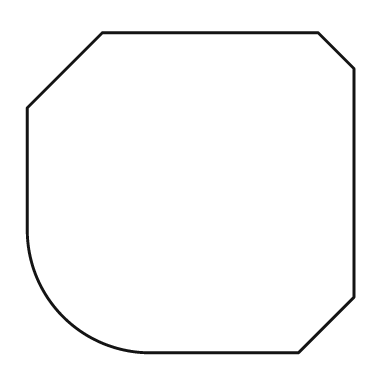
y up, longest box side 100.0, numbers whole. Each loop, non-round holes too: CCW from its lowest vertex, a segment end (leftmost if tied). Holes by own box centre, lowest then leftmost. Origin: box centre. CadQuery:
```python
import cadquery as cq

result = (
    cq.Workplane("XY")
    .moveTo(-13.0, -49.0)
    .lineTo(33.0, -49.0)
    .lineTo(50.0, -32.0)
    .lineTo(50.0, 38.0)
    .lineTo(39.0, 49.0)
    .lineTo(-27.0, 49.0)
    .lineTo(-50.0, 26.0)
    .lineTo(-50.0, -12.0)
    .threePointArc((-39.0, -38.0), (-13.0, -49.0))
    .close()
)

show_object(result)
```